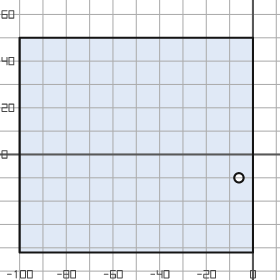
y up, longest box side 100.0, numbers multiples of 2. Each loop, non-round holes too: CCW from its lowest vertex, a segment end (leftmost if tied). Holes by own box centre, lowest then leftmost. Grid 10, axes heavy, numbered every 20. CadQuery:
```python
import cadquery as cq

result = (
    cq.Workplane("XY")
    .moveTo(-100.0, -42.0)
    .lineTo(0.0, -42.0)
    .lineTo(0.0, 50.0)
    .lineTo(-100.0, 50.0)
    .close()
    .moveTo(-6.0, -10.0)
    .circle(2.0)
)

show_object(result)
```